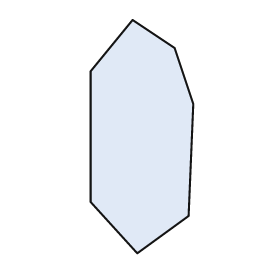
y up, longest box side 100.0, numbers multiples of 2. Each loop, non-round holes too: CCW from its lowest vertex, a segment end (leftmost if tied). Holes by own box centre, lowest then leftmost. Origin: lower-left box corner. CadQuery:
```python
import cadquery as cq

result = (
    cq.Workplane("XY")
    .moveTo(20.0, 0.0)
    .lineTo(42.0, 16.0)
    .lineTo(44.0, 64.0)
    .lineTo(36.0, 88.0)
    .lineTo(18.0, 100.0)
    .lineTo(0.0, 78.0)
    .lineTo(0.0, 22.0)
    .close()
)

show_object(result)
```